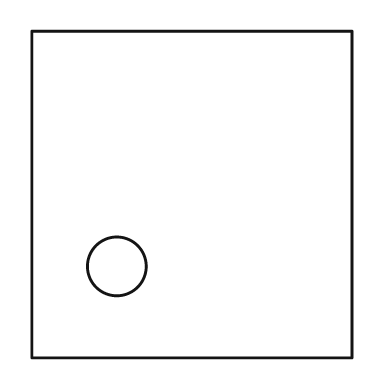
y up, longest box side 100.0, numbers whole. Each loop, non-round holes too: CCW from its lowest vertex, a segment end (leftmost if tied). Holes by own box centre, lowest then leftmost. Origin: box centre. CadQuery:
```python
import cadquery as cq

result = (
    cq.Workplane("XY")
    .moveTo(-49.0, -50.0)
    .lineTo(49.0, -50.0)
    .lineTo(49.0, 50.0)
    .lineTo(-49.0, 50.0)
    .close()
    .moveTo(-23.0, -22.0)
    .circle(9.0)
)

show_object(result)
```